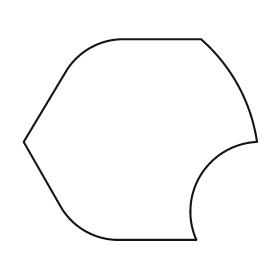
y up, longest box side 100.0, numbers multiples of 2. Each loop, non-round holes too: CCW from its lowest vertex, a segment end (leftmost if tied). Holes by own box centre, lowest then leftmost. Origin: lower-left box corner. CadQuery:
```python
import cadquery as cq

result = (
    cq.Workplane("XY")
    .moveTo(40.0, 0.0)
    .lineTo(74.0, 0.0)
    .threePointArc((76.0, 28.0), (100.0, 42.0))
    .threePointArc((92.0, 66.0), (76.0, 86.0))
    .lineTo(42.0, 86.0)
    .threePointArc((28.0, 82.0), (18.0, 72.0))
    .lineTo(0.0, 42.0)
    .lineTo(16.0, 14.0)
    .threePointArc((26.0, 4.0), (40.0, 0.0))
    .close()
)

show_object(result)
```